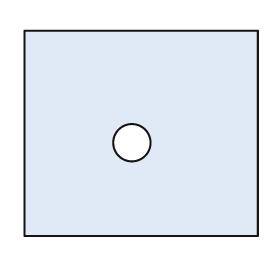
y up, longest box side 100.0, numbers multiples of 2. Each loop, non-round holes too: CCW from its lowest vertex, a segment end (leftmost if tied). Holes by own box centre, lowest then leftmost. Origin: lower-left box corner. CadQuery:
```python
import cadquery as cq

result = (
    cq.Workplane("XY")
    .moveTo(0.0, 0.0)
    .lineTo(100.0, 0.0)
    .lineTo(100.0, 88.0)
    .lineTo(0.0, 88.0)
    .close()
    .moveTo(46.0, 40.0)
    .circle(8.0)
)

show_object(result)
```